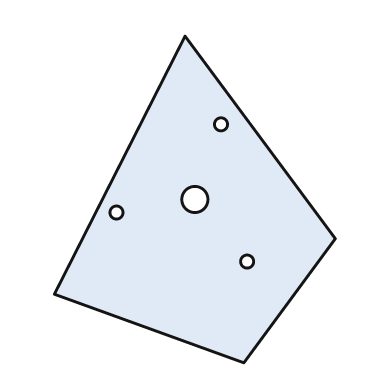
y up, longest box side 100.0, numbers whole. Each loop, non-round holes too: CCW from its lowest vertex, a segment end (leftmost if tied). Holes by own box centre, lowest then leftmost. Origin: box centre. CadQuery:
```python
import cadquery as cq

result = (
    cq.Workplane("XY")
    .moveTo(15.0, -50.0)
    .lineTo(43.0, -12.0)
    .lineTo(-3.0, 50.0)
    .lineTo(-43.0, -29.0)
    .close()
    .moveTo(16.0, -19.0)
    .circle(2.0)
    .moveTo(-24.0, -4.0)
    .circle(2.0)
    .moveTo(0.0, 0.0)
    .circle(4.0)
    .moveTo(8.0, 23.0)
    .circle(2.0)
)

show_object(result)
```